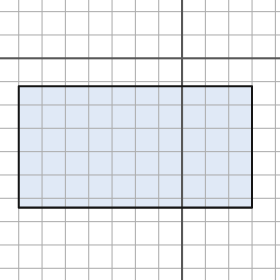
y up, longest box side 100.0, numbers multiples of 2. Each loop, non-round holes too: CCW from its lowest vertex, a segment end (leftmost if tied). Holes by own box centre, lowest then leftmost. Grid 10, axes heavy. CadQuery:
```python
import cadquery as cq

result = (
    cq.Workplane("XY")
    .moveTo(-70.0, -64.0)
    .lineTo(30.0, -64.0)
    .lineTo(30.0, -12.0)
    .lineTo(-70.0, -12.0)
    .close()
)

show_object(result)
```